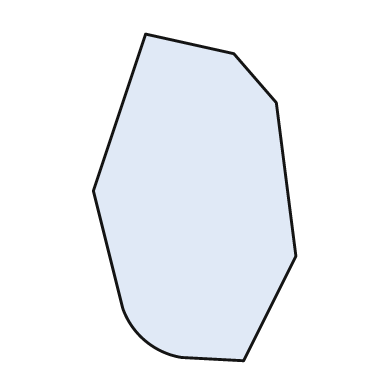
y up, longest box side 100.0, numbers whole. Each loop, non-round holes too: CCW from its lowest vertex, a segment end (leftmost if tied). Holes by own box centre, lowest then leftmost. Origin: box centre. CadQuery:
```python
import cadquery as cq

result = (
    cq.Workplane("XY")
    .moveTo(15.0, -50.0)
    .lineTo(31.0, -18.0)
    .lineTo(25.0, 29.0)
    .lineTo(12.0, 44.0)
    .lineTo(-15.0, 50.0)
    .lineTo(-31.0, 2.0)
    .lineTo(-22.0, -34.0)
    .threePointArc((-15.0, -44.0), (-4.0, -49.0))
    .close()
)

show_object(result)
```